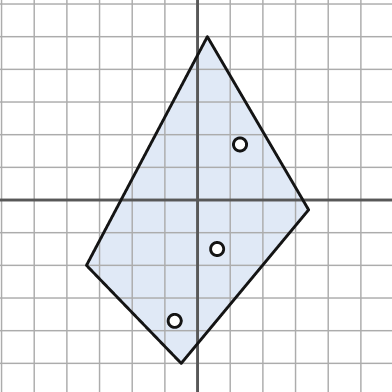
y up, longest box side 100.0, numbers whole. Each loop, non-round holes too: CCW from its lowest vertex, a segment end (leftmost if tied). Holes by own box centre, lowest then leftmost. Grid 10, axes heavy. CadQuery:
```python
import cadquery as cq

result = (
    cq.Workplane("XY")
    .moveTo(-5.0, -50.0)
    .lineTo(34.0, -3.0)
    .lineTo(3.0, 50.0)
    .lineTo(-34.0, -20.0)
    .close()
    .moveTo(-7.0, -37.0)
    .circle(2.0)
    .moveTo(6.0, -15.0)
    .circle(2.0)
    .moveTo(13.0, 17.0)
    .circle(2.0)
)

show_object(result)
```